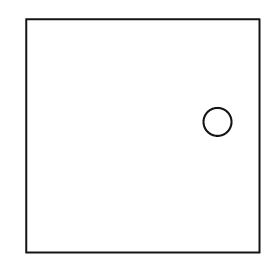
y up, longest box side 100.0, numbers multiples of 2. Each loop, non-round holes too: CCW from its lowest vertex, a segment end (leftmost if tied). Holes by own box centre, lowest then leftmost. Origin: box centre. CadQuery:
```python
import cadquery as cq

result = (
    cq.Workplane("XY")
    .moveTo(-50.0, -50.0)
    .lineTo(50.0, -50.0)
    .lineTo(50.0, 50.0)
    .lineTo(-50.0, 50.0)
    .close()
    .moveTo(32.0, 6.0)
    .circle(6.0)
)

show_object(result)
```